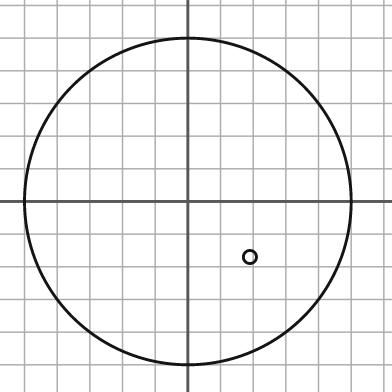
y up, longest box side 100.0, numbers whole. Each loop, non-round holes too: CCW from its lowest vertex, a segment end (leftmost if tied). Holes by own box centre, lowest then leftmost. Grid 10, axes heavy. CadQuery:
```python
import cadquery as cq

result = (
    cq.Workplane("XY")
    .moveTo(0.0, 0.0)
    .circle(50.0)
    .moveTo(19.0, -17.0)
    .circle(2.0)
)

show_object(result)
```